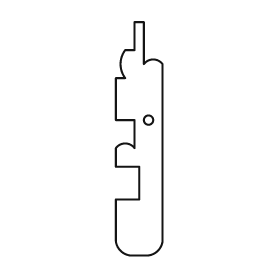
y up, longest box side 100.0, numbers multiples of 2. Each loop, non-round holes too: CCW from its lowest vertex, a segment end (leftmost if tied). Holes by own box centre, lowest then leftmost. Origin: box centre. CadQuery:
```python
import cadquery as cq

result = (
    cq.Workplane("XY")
    .moveTo(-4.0, -50.0)
    .lineTo(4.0, -50.0)
    .threePointArc((8.0, -48.0), (10.0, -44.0))
    .lineTo(10.0, 32.0)
    .threePointArc((6.0, 34.0), (2.0, 32.0))
    .lineTo(2.0, 50.0)
    .lineTo(-2.0, 50.0)
    .lineTo(-2.0, 38.0)
    .lineTo(-6.0, 38.0)
    .threePointArc((-8.0, 32.0), (-6.0, 26.0))
    .lineTo(-10.0, 26.0)
    .lineTo(-10.0, 8.0)
    .lineTo(-2.0, 8.0)
    .lineTo(-2.0, -4.0)
    .threePointArc((-6.0, -2.0), (-10.0, -4.0))
    .lineTo(-10.0, -12.0)
    .lineTo(0.0, -12.0)
    .lineTo(0.0, -26.0)
    .lineTo(-10.0, -26.0)
    .lineTo(-10.0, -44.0)
    .threePointArc((-8.0, -48.0), (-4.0, -50.0))
    .close()
    .moveTo(4.0, 8.0)
    .circle(2.0)
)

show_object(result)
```